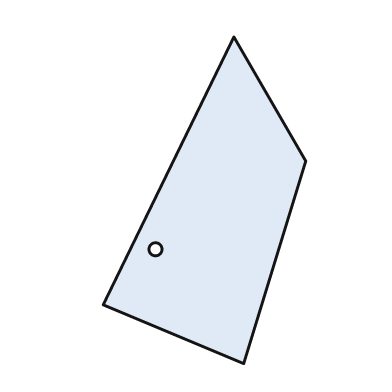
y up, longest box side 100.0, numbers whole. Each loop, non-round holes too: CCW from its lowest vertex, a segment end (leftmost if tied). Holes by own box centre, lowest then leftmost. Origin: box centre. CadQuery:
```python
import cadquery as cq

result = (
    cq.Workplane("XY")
    .moveTo(12.0, -50.0)
    .lineTo(31.0, 12.0)
    .lineTo(9.0, 50.0)
    .lineTo(-31.0, -32.0)
    .close()
    .moveTo(-15.0, -15.0)
    .circle(2.0)
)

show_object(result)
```